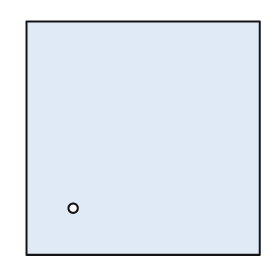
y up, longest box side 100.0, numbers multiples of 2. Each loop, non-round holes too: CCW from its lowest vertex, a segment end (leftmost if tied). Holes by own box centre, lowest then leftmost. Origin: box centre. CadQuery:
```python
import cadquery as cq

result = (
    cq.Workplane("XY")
    .moveTo(-50.0, -50.0)
    .lineTo(50.0, -50.0)
    .lineTo(50.0, 50.0)
    .lineTo(-50.0, 50.0)
    .close()
    .moveTo(-30.0, -30.0)
    .circle(2.0)
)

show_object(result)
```